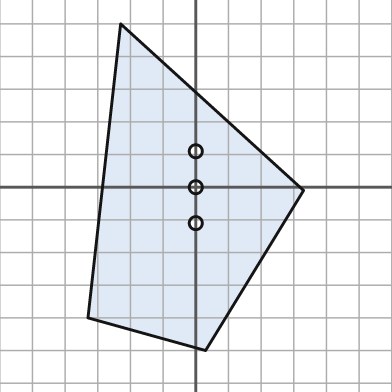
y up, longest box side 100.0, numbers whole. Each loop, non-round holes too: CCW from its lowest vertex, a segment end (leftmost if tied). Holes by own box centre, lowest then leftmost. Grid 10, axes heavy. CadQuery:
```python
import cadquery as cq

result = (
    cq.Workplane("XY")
    .moveTo(3.0, -50.0)
    .lineTo(33.0, -1.0)
    .lineTo(-23.0, 50.0)
    .lineTo(-33.0, -40.0)
    .close()
    .moveTo(0.0, -11.0)
    .circle(2.0)
    .moveTo(0.0, 0.0)
    .circle(2.0)
    .moveTo(0.0, 11.0)
    .circle(2.0)
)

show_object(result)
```